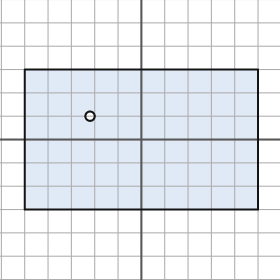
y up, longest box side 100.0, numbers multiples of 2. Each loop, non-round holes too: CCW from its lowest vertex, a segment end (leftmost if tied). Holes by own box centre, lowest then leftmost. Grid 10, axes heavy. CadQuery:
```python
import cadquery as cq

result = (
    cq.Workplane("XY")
    .moveTo(-50.0, -30.0)
    .lineTo(50.0, -30.0)
    .lineTo(50.0, 30.0)
    .lineTo(-50.0, 30.0)
    .close()
    .moveTo(-22.0, 10.0)
    .circle(2.0)
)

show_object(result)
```